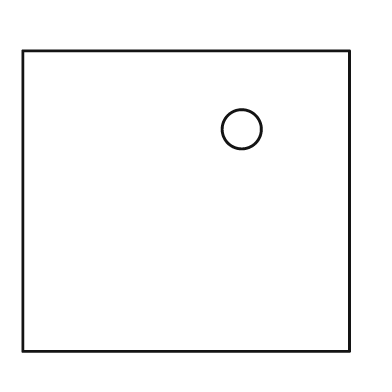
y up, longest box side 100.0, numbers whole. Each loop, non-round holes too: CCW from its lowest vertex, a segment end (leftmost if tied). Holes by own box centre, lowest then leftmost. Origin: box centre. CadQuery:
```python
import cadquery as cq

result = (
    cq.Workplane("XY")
    .moveTo(-50.0, -46.0)
    .lineTo(50.0, -46.0)
    .lineTo(50.0, 46.0)
    .lineTo(-50.0, 46.0)
    .close()
    .moveTo(17.0, 22.0)
    .circle(6.0)
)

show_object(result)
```